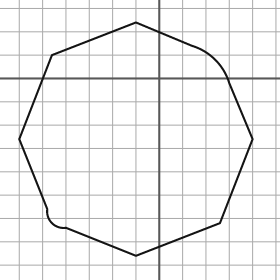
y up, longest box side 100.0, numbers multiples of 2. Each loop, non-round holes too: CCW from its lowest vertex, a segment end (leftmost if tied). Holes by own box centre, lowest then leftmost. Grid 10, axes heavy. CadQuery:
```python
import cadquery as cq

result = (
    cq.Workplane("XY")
    .moveTo(-10.0, -76.0)
    .lineTo(26.0, -62.0)
    .lineTo(40.0, -26.0)
    .lineTo(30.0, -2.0)
    .threePointArc((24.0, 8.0), (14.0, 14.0))
    .lineTo(-10.0, 24.0)
    .lineTo(-46.0, 10.0)
    .lineTo(-60.0, -26.0)
    .lineTo(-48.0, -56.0)
    .threePointArc((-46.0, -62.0), (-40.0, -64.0))
    .close()
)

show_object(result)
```